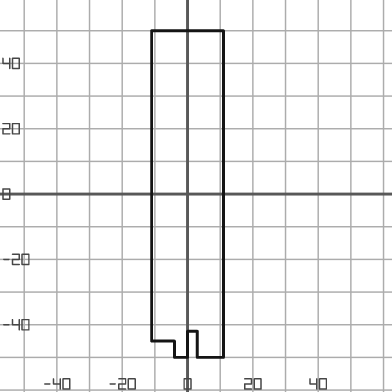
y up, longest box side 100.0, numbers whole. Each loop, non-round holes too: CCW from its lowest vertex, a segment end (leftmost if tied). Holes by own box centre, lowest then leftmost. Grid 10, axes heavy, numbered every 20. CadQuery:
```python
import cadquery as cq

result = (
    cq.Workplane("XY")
    .moveTo(-4.0, -50.0)
    .lineTo(0.0, -50.0)
    .lineTo(0.0, -42.0)
    .lineTo(3.0, -42.0)
    .lineTo(3.0, -50.0)
    .lineTo(11.0, -50.0)
    .lineTo(11.0, 50.0)
    .lineTo(-11.0, 50.0)
    .lineTo(-11.0, -45.0)
    .lineTo(-4.0, -45.0)
    .close()
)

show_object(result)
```